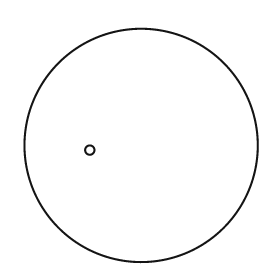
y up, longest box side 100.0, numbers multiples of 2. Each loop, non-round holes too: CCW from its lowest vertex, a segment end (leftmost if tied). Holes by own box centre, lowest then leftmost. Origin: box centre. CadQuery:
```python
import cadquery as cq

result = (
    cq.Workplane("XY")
    .moveTo(0.0, 0.0)
    .circle(50.0)
    .moveTo(-22.0, -2.0)
    .circle(2.0)
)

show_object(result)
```